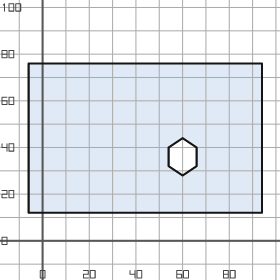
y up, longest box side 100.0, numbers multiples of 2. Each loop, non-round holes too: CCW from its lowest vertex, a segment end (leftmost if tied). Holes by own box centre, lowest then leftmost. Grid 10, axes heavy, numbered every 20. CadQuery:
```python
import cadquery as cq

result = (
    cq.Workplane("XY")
    .moveTo(-6.0, 12.0)
    .lineTo(94.0, 12.0)
    .lineTo(94.0, 76.0)
    .lineTo(-6.0, 76.0)
    .close()
    .moveTo(60.0, 28.0)
    .lineTo(66.0, 32.0)
    .lineTo(66.0, 40.0)
    .lineTo(60.0, 44.0)
    .lineTo(54.0, 40.0)
    .lineTo(54.0, 32.0)
    .close()
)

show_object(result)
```